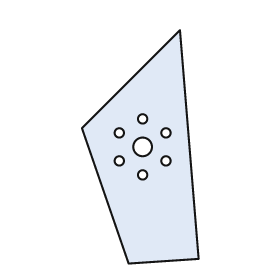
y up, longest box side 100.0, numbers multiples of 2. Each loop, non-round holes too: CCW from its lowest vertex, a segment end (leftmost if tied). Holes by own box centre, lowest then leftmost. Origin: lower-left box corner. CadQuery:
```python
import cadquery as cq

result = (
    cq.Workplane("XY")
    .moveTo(20.0, 0.0)
    .lineTo(50.0, 2.0)
    .lineTo(42.0, 100.0)
    .lineTo(0.0, 58.0)
    .close()
    .moveTo(26.0, 38.0)
    .circle(2.0)
    .moveTo(16.0, 44.0)
    .circle(2.0)
    .moveTo(36.0, 44.0)
    .circle(2.0)
    .moveTo(26.0, 50.0)
    .circle(4.0)
    .moveTo(16.0, 56.0)
    .circle(2.0)
    .moveTo(36.0, 56.0)
    .circle(2.0)
    .moveTo(26.0, 62.0)
    .circle(2.0)
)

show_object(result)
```